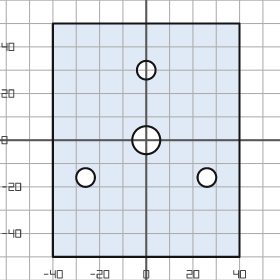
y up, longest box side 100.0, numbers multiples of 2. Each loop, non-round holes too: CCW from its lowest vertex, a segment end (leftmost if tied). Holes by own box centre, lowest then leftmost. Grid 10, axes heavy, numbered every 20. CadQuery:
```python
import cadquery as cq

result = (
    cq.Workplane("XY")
    .moveTo(-40.0, -50.0)
    .lineTo(40.0, -50.0)
    .lineTo(40.0, 50.0)
    .lineTo(-40.0, 50.0)
    .close()
    .moveTo(-26.0, -16.0)
    .circle(4.0)
    .moveTo(26.0, -16.0)
    .circle(4.0)
    .moveTo(0.0, 0.0)
    .circle(6.0)
    .moveTo(0.0, 30.0)
    .circle(4.0)
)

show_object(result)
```